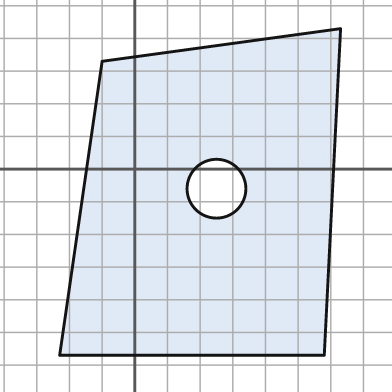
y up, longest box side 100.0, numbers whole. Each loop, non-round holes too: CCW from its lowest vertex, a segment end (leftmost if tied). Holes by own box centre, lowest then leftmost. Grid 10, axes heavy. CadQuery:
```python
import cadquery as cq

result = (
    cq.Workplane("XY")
    .moveTo(-23.0, -57.0)
    .lineTo(58.0, -57.0)
    .lineTo(63.0, 43.0)
    .lineTo(-10.0, 33.0)
    .close()
    .moveTo(25.0, -6.0)
    .circle(9.0)
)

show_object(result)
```